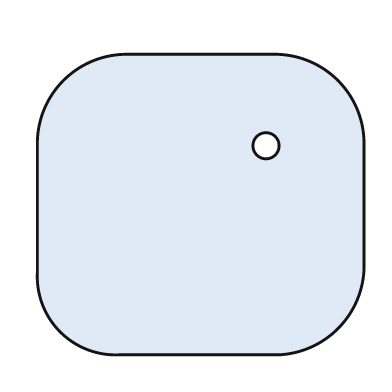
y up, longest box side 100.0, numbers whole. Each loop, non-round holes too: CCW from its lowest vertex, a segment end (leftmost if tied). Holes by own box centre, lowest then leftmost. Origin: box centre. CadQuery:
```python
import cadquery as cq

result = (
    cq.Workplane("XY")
    .moveTo(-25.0, -46.0)
    .lineTo(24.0, -46.0)
    .threePointArc((42.0, -38.0), (50.0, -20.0))
    .lineTo(50.0, 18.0)
    .threePointArc((42.0, 38.0), (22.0, 46.0))
    .lineTo(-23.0, 46.0)
    .threePointArc((-42.0, 38.0), (-50.0, 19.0))
    .lineTo(-50.0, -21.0)
    .threePointArc((-43.0, -39.0), (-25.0, -46.0))
    .close()
    .moveTo(20.0, 18.0)
    .circle(4.0)
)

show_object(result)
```